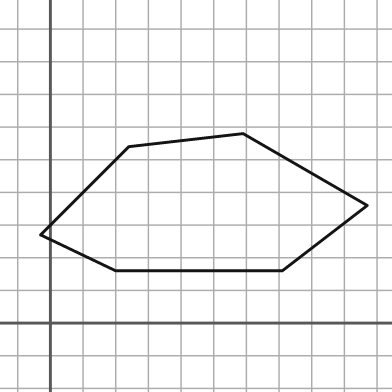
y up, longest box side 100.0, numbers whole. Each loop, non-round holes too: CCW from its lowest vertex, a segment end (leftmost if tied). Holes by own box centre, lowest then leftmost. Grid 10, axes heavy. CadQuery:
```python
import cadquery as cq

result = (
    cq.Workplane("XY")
    .moveTo(20.0, 16.0)
    .lineTo(71.0, 16.0)
    .lineTo(97.0, 36.0)
    .lineTo(59.0, 58.0)
    .lineTo(24.0, 54.0)
    .lineTo(-3.0, 27.0)
    .close()
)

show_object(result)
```